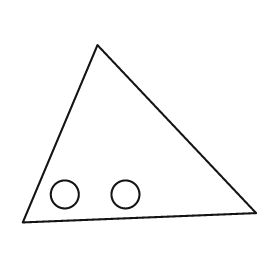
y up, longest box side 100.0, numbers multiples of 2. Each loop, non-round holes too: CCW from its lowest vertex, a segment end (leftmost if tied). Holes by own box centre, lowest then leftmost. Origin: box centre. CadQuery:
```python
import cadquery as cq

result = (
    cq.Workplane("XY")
    .moveTo(-50.0, -38.0)
    .lineTo(50.0, -34.0)
    .lineTo(-18.0, 38.0)
    .close()
    .moveTo(-32.0, -26.0)
    .circle(6.0)
    .moveTo(-6.0, -26.0)
    .circle(6.0)
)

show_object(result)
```